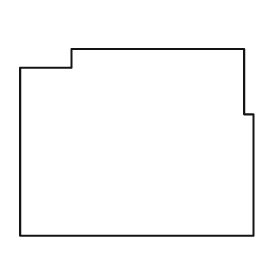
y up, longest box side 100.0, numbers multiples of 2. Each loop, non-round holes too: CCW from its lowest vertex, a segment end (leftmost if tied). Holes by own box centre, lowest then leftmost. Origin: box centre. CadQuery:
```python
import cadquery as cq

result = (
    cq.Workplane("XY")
    .moveTo(-50.0, -40.0)
    .lineTo(50.0, -40.0)
    .lineTo(50.0, 12.0)
    .lineTo(46.0, 12.0)
    .lineTo(46.0, 40.0)
    .lineTo(-28.0, 40.0)
    .lineTo(-28.0, 32.0)
    .lineTo(-50.0, 32.0)
    .close()
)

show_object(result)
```